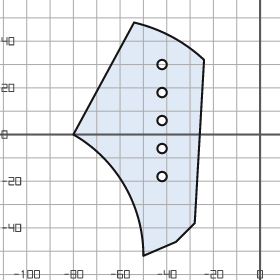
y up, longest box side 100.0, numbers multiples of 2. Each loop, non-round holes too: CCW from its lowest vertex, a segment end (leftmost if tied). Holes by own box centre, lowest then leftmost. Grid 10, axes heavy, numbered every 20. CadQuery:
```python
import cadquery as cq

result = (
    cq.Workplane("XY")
    .moveTo(-50.0, -52.0)
    .lineTo(-36.0, -46.0)
    .lineTo(-28.0, -38.0)
    .lineTo(-24.0, 32.0)
    .threePointArc((-38.0, 42.0), (-54.0, 48.0))
    .lineTo(-80.0, 0.0)
    .threePointArc((-58.0, -22.0), (-50.0, -52.0))
    .close()
    .moveTo(-42.0, -18.0)
    .circle(2.0)
    .moveTo(-42.0, -6.0)
    .circle(2.0)
    .moveTo(-42.0, 6.0)
    .circle(2.0)
    .moveTo(-42.0, 18.0)
    .circle(2.0)
    .moveTo(-42.0, 30.0)
    .circle(2.0)
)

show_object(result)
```